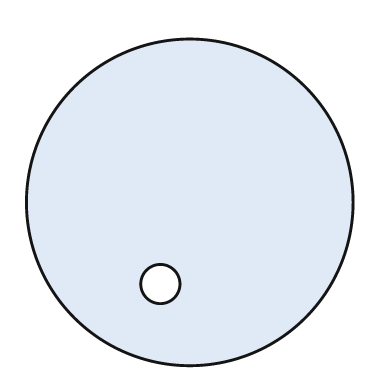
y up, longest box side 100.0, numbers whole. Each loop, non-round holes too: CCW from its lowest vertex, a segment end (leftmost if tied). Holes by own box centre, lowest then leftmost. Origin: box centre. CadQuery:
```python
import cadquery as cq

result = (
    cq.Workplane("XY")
    .moveTo(0.0, 0.0)
    .circle(50.0)
    .moveTo(-9.0, -25.0)
    .circle(6.0)
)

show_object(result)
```